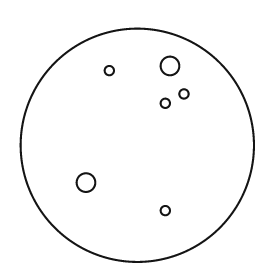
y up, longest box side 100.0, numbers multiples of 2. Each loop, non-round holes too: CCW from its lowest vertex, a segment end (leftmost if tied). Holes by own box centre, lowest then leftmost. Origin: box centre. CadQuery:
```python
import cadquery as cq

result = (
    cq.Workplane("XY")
    .moveTo(0.0, 0.0)
    .circle(50.0)
    .moveTo(12.0, -28.0)
    .circle(2.0)
    .moveTo(-22.0, -16.0)
    .circle(4.0)
    .moveTo(12.0, 18.0)
    .circle(2.0)
    .moveTo(20.0, 22.0)
    .circle(2.0)
    .moveTo(-12.0, 32.0)
    .circle(2.0)
    .moveTo(14.0, 34.0)
    .circle(4.0)
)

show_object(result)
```